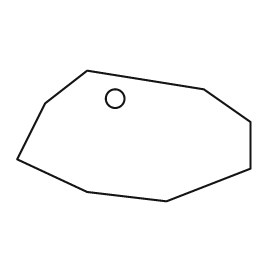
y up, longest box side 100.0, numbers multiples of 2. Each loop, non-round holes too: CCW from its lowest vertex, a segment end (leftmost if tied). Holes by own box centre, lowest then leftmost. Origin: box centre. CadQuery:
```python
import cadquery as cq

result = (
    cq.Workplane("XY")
    .moveTo(14.0, -28.0)
    .lineTo(50.0, -14.0)
    .lineTo(50.0, 6.0)
    .lineTo(30.0, 20.0)
    .lineTo(-20.0, 28.0)
    .lineTo(-38.0, 14.0)
    .lineTo(-50.0, -10.0)
    .lineTo(-20.0, -24.0)
    .close()
    .moveTo(-8.0, 16.0)
    .circle(4.0)
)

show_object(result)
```